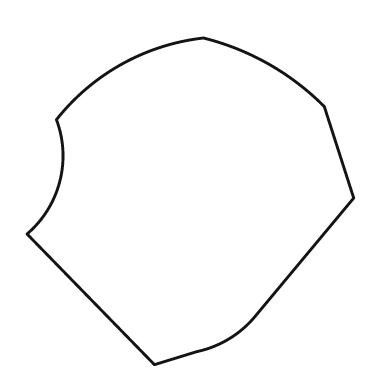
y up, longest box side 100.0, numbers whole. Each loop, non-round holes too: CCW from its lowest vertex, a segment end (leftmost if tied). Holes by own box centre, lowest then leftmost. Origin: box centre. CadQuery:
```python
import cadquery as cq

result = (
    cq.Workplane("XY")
    .moveTo(-11.0, -50.0)
    .lineTo(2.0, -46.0)
    .threePointArc((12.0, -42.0), (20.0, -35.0))
    .lineTo(50.0, 1.0)
    .lineTo(41.0, 29.0)
    .threePointArc((24.0, 42.0), (4.0, 50.0))
    .threePointArc((-21.0, 42.0), (-41.0, 25.0))
    .threePointArc((-40.0, 6.0), (-50.0, -10.0))
    .close()
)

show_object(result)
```